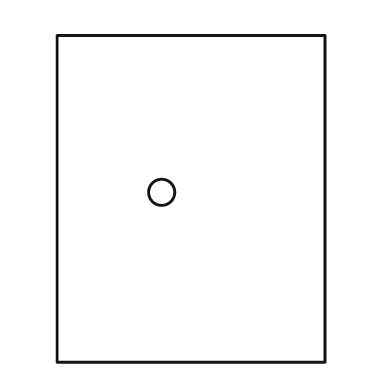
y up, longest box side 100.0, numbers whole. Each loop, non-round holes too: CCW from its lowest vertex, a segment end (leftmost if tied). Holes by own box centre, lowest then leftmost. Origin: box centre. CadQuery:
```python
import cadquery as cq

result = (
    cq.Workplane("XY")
    .moveTo(-41.0, -50.0)
    .lineTo(41.0, -50.0)
    .lineTo(41.0, 50.0)
    .lineTo(-41.0, 50.0)
    .close()
    .moveTo(-9.0, 2.0)
    .circle(4.0)
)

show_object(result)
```